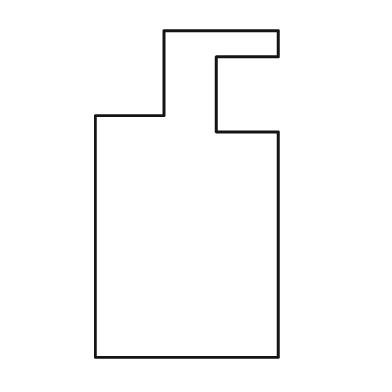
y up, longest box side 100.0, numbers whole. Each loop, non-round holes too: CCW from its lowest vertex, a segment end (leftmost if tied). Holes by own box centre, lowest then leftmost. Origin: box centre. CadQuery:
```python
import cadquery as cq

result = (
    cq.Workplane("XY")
    .moveTo(-28.0, -50.0)
    .lineTo(28.0, -50.0)
    .lineTo(28.0, 19.0)
    .lineTo(9.0, 19.0)
    .lineTo(9.0, 42.0)
    .lineTo(28.0, 42.0)
    .lineTo(28.0, 50.0)
    .lineTo(-7.0, 50.0)
    .lineTo(-7.0, 24.0)
    .lineTo(-28.0, 24.0)
    .close()
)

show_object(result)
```